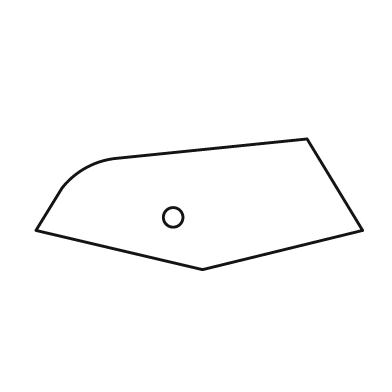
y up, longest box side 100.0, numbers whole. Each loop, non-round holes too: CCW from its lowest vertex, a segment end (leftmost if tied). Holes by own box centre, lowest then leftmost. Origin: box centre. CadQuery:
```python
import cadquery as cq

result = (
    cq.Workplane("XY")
    .moveTo(1.0, -20.0)
    .lineTo(50.0, -8.0)
    .lineTo(33.0, 20.0)
    .lineTo(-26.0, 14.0)
    .threePointArc((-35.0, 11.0), (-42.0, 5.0))
    .lineTo(-50.0, -8.0)
    .close()
    .moveTo(-8.0, -4.0)
    .circle(3.0)
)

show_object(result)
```